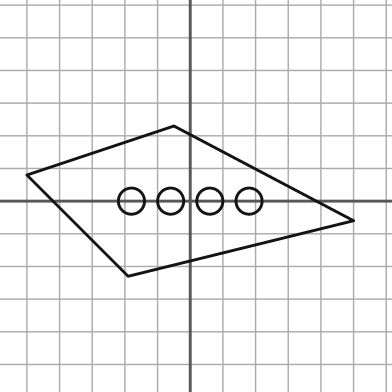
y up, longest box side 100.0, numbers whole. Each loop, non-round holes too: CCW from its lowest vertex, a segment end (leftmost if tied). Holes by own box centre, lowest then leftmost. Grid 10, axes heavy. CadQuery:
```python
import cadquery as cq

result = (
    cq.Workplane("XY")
    .moveTo(-19.0, -23.0)
    .lineTo(50.0, -6.0)
    .lineTo(-5.0, 23.0)
    .lineTo(-50.0, 8.0)
    .close()
    .moveTo(-18.0, 0.0)
    .circle(4.0)
    .moveTo(-6.0, 0.0)
    .circle(4.0)
    .moveTo(6.0, 0.0)
    .circle(4.0)
    .moveTo(18.0, 0.0)
    .circle(4.0)
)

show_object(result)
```